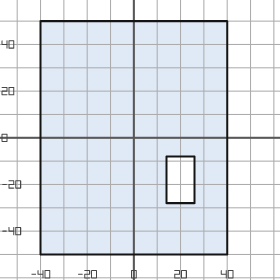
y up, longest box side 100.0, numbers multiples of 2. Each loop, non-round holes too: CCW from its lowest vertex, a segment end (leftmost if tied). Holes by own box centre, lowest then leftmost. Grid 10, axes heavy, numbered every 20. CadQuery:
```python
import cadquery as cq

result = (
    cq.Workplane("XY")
    .moveTo(-40.0, -50.0)
    .lineTo(40.0, -50.0)
    .lineTo(40.0, 50.0)
    .lineTo(-40.0, 50.0)
    .close()
    .moveTo(14.0, -28.0)
    .lineTo(26.0, -28.0)
    .lineTo(26.0, -8.0)
    .lineTo(14.0, -8.0)
    .close()
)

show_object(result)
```